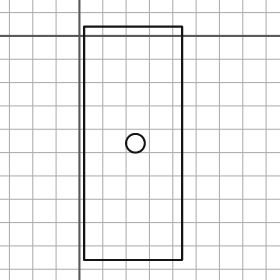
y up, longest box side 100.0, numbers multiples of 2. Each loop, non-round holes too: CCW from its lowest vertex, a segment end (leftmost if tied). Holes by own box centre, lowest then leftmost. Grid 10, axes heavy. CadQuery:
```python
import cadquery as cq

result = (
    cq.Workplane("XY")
    .moveTo(2.0, -96.0)
    .lineTo(44.0, -96.0)
    .lineTo(44.0, 4.0)
    .lineTo(2.0, 4.0)
    .close()
    .moveTo(24.0, -46.0)
    .circle(4.0)
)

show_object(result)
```